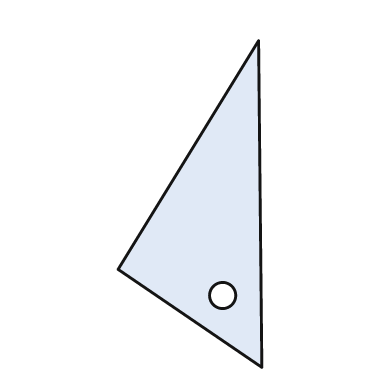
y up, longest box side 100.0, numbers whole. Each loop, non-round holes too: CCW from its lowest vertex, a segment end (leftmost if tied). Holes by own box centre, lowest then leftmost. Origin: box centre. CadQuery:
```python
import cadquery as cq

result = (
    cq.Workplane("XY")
    .moveTo(22.0, -50.0)
    .lineTo(21.0, 50.0)
    .lineTo(-22.0, -20.0)
    .close()
    .moveTo(10.0, -28.0)
    .circle(4.0)
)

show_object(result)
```